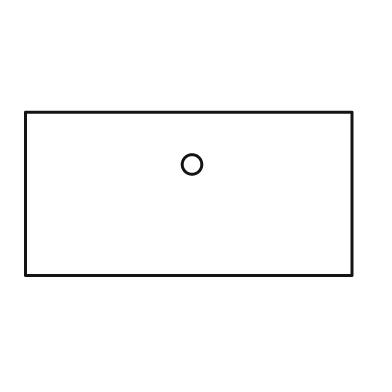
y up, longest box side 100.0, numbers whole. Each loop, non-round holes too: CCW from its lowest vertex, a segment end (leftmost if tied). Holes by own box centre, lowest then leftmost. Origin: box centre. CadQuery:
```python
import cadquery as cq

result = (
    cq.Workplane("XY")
    .moveTo(-50.0, -25.0)
    .lineTo(50.0, -25.0)
    .lineTo(50.0, 25.0)
    .lineTo(-50.0, 25.0)
    .close()
    .moveTo(1.0, 9.0)
    .circle(3.0)
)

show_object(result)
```